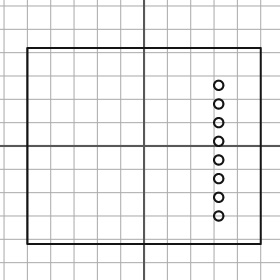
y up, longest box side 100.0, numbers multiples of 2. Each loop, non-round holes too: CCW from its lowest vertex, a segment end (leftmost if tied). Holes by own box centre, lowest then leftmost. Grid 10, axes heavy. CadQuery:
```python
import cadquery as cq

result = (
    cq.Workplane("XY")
    .moveTo(-50.0, -42.0)
    .lineTo(50.0, -42.0)
    .lineTo(50.0, 42.0)
    .lineTo(-50.0, 42.0)
    .close()
    .moveTo(32.0, -30.0)
    .circle(2.0)
    .moveTo(32.0, -22.0)
    .circle(2.0)
    .moveTo(32.0, -14.0)
    .circle(2.0)
    .moveTo(32.0, -6.0)
    .circle(2.0)
    .moveTo(32.0, 2.0)
    .circle(2.0)
    .moveTo(32.0, 10.0)
    .circle(2.0)
    .moveTo(32.0, 18.0)
    .circle(2.0)
    .moveTo(32.0, 26.0)
    .circle(2.0)
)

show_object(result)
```